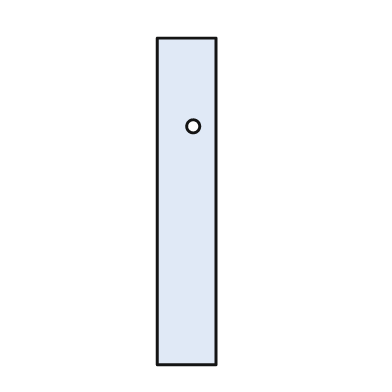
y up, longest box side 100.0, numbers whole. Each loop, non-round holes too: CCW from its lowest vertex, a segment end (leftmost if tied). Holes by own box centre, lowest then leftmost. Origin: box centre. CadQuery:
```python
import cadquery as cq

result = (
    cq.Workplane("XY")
    .moveTo(-9.0, -50.0)
    .lineTo(9.0, -50.0)
    .lineTo(9.0, 50.0)
    .lineTo(-9.0, 50.0)
    .close()
    .moveTo(2.0, 23.0)
    .circle(2.0)
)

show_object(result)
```